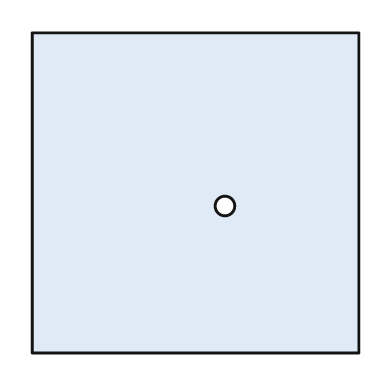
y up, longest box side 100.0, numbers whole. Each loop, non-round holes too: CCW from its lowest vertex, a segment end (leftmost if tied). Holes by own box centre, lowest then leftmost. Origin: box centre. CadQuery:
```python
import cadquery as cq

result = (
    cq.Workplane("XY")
    .moveTo(-50.0, -49.0)
    .lineTo(50.0, -49.0)
    .lineTo(50.0, 49.0)
    .lineTo(-50.0, 49.0)
    .close()
    .moveTo(9.0, -4.0)
    .circle(3.0)
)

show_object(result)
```